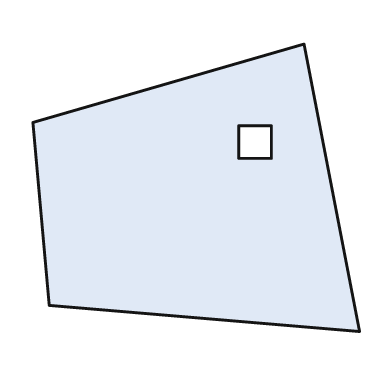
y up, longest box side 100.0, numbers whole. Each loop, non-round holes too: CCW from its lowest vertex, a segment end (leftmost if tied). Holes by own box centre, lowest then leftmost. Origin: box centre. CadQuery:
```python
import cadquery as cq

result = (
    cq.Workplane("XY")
    .moveTo(50.0, -44.0)
    .lineTo(33.0, 44.0)
    .lineTo(-50.0, 20.0)
    .lineTo(-45.0, -36.0)
    .close()
    .moveTo(13.0, 9.0)
    .lineTo(23.0, 9.0)
    .lineTo(23.0, 19.0)
    .lineTo(13.0, 19.0)
    .close()
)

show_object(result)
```